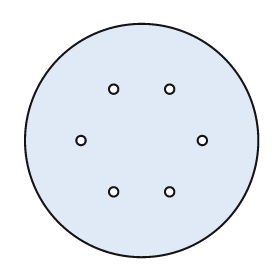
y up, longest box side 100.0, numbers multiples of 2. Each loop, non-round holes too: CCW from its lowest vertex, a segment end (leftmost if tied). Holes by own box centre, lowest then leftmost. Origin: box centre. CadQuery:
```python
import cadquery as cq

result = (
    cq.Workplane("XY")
    .moveTo(0.0, 0.0)
    .circle(50.0)
    .moveTo(-12.0, -22.0)
    .circle(2.0)
    .moveTo(12.0, -22.0)
    .circle(2.0)
    .moveTo(-26.0, 0.0)
    .circle(2.0)
    .moveTo(26.0, 0.0)
    .circle(2.0)
    .moveTo(-12.0, 22.0)
    .circle(2.0)
    .moveTo(12.0, 22.0)
    .circle(2.0)
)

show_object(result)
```